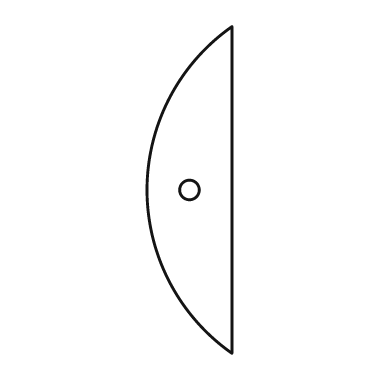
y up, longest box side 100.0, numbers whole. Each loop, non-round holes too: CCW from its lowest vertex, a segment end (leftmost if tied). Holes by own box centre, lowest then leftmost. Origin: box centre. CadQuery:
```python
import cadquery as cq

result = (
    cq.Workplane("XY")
    .moveTo(13.0, -50.0)
    .lineTo(13.0, 50.0)
    .threePointArc((-13.0, 0.0), (13.0, -50.0))
    .close()
    .moveTo(0.0, 0.0)
    .circle(3.0)
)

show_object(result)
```